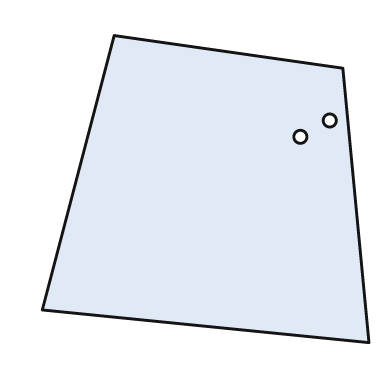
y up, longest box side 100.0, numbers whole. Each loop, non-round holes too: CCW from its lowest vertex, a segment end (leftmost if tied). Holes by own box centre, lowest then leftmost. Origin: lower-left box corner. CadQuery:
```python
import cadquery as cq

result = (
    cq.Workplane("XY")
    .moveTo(100.0, 0.0)
    .lineTo(92.0, 84.0)
    .lineTo(22.0, 94.0)
    .lineTo(0.0, 10.0)
    .close()
    .moveTo(79.0, 63.0)
    .circle(2.0)
    .moveTo(88.0, 68.0)
    .circle(2.0)
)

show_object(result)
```